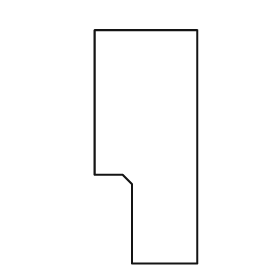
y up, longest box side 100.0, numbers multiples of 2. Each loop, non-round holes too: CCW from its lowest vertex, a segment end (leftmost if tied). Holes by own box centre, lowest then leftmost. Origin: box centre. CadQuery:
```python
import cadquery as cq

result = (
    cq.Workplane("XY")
    .moveTo(-6.0, -50.0)
    .lineTo(22.0, -50.0)
    .lineTo(22.0, 50.0)
    .lineTo(-22.0, 50.0)
    .lineTo(-22.0, -12.0)
    .lineTo(-10.0, -12.0)
    .lineTo(-6.0, -16.0)
    .close()
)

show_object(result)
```